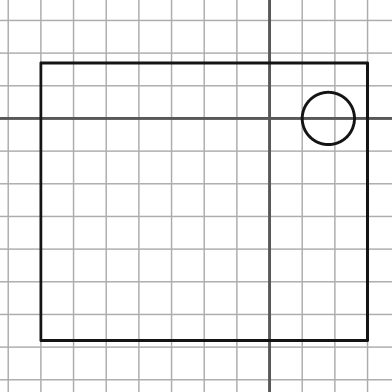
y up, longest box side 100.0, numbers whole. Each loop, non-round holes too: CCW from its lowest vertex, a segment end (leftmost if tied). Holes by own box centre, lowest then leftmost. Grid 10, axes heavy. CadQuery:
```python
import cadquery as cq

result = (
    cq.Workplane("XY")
    .moveTo(-70.0, -68.0)
    .lineTo(30.0, -68.0)
    .lineTo(30.0, 17.0)
    .lineTo(-70.0, 17.0)
    .close()
    .moveTo(18.0, 0.0)
    .circle(8.0)
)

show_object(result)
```